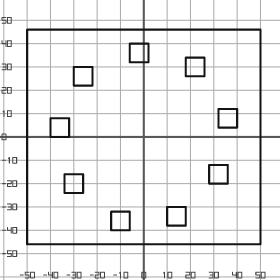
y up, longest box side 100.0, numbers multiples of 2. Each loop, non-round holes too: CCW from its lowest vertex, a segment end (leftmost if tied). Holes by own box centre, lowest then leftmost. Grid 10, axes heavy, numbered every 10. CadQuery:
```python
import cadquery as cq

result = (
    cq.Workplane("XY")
    .moveTo(-50.0, -46.0)
    .lineTo(50.0, -46.0)
    .lineTo(50.0, 46.0)
    .lineTo(-50.0, 46.0)
    .close()
    .moveTo(-14.0, -40.0)
    .lineTo(-6.0, -40.0)
    .lineTo(-6.0, -32.0)
    .lineTo(-14.0, -32.0)
    .close()
    .moveTo(10.0, -38.0)
    .lineTo(18.0, -38.0)
    .lineTo(18.0, -30.0)
    .lineTo(10.0, -30.0)
    .close()
    .moveTo(-34.0, -24.0)
    .lineTo(-26.0, -24.0)
    .lineTo(-26.0, -16.0)
    .lineTo(-34.0, -16.0)
    .close()
    .moveTo(28.0, -20.0)
    .lineTo(36.0, -20.0)
    .lineTo(36.0, -12.0)
    .lineTo(28.0, -12.0)
    .close()
    .moveTo(-40.0, 0.0)
    .lineTo(-32.0, 0.0)
    .lineTo(-32.0, 8.0)
    .lineTo(-40.0, 8.0)
    .close()
    .moveTo(32.0, 4.0)
    .lineTo(40.0, 4.0)
    .lineTo(40.0, 12.0)
    .lineTo(32.0, 12.0)
    .close()
    .moveTo(-30.0, 22.0)
    .lineTo(-22.0, 22.0)
    .lineTo(-22.0, 30.0)
    .lineTo(-30.0, 30.0)
    .close()
    .moveTo(18.0, 26.0)
    .lineTo(26.0, 26.0)
    .lineTo(26.0, 34.0)
    .lineTo(18.0, 34.0)
    .close()
    .moveTo(-6.0, 32.0)
    .lineTo(2.0, 32.0)
    .lineTo(2.0, 40.0)
    .lineTo(-6.0, 40.0)
    .close()
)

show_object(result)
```